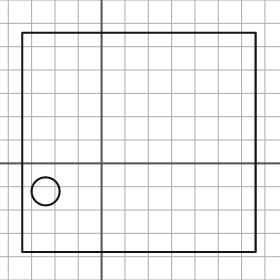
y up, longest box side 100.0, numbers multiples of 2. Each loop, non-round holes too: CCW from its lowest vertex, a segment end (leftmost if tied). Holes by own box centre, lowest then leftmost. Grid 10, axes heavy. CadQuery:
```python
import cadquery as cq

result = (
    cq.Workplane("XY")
    .moveTo(-34.0, -38.0)
    .lineTo(66.0, -38.0)
    .lineTo(66.0, 56.0)
    .lineTo(-34.0, 56.0)
    .close()
    .moveTo(-24.0, -12.0)
    .circle(6.0)
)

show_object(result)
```